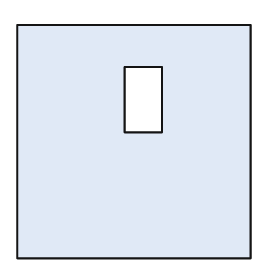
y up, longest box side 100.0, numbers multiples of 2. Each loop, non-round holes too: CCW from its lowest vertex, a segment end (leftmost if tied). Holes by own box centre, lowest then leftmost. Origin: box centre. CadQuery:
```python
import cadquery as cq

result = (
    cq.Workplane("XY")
    .moveTo(-50.0, -50.0)
    .lineTo(50.0, -50.0)
    .lineTo(50.0, 50.0)
    .lineTo(-50.0, 50.0)
    .close()
    .moveTo(-4.0, 4.0)
    .lineTo(12.0, 4.0)
    .lineTo(12.0, 32.0)
    .lineTo(-4.0, 32.0)
    .close()
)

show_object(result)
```